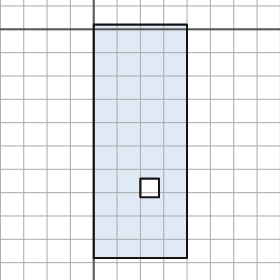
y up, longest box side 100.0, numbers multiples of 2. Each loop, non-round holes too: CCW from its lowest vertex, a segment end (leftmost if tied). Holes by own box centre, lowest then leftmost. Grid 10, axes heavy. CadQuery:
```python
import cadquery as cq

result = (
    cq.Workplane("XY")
    .moveTo(0.0, -98.0)
    .lineTo(40.0, -98.0)
    .lineTo(40.0, 2.0)
    .lineTo(0.0, 2.0)
    .close()
    .moveTo(20.0, -72.0)
    .lineTo(28.0, -72.0)
    .lineTo(28.0, -64.0)
    .lineTo(20.0, -64.0)
    .close()
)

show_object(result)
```